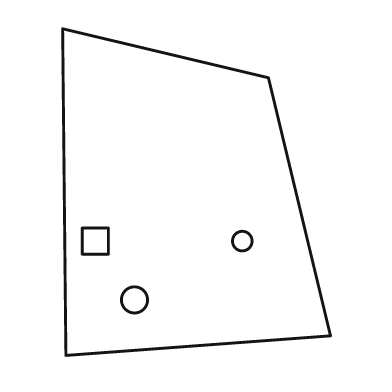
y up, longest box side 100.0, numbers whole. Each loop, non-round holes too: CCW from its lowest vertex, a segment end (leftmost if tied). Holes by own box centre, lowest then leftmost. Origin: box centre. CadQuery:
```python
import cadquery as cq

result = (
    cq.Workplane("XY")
    .moveTo(-40.0, -50.0)
    .lineTo(41.0, -44.0)
    .lineTo(22.0, 35.0)
    .lineTo(-41.0, 50.0)
    .close()
    .moveTo(-19.0, -33.0)
    .circle(4.0)
    .moveTo(-35.0, -19.0)
    .lineTo(-27.0, -19.0)
    .lineTo(-27.0, -11.0)
    .lineTo(-35.0, -11.0)
    .close()
    .moveTo(14.0, -15.0)
    .circle(3.0)
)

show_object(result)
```